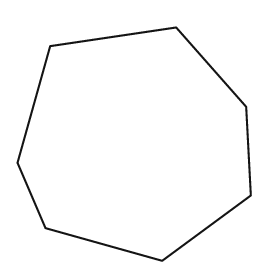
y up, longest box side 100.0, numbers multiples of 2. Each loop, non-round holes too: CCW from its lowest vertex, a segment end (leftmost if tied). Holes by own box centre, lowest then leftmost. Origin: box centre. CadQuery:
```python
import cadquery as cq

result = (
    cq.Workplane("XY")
    .moveTo(12.0, -50.0)
    .lineTo(50.0, -22.0)
    .lineTo(48.0, 16.0)
    .lineTo(18.0, 50.0)
    .lineTo(-36.0, 42.0)
    .lineTo(-50.0, -8.0)
    .lineTo(-38.0, -36.0)
    .close()
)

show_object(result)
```